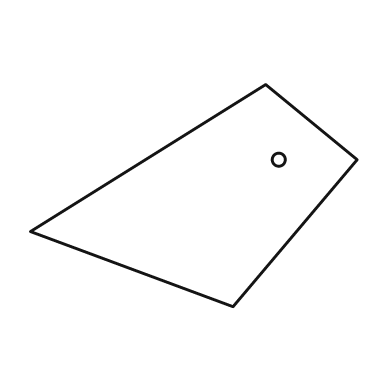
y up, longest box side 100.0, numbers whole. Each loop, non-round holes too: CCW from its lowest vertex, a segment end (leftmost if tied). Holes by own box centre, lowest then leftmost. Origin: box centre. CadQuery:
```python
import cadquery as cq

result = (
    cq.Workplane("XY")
    .moveTo(12.0, -34.0)
    .lineTo(50.0, 11.0)
    .lineTo(22.0, 34.0)
    .lineTo(-50.0, -11.0)
    .close()
    .moveTo(26.0, 11.0)
    .circle(2.0)
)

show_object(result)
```